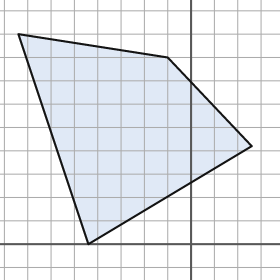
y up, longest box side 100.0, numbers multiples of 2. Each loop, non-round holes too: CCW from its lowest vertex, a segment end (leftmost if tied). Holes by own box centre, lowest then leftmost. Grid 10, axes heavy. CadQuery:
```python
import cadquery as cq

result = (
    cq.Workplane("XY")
    .moveTo(-44.0, 0.0)
    .lineTo(26.0, 42.0)
    .lineTo(-10.0, 80.0)
    .lineTo(-74.0, 90.0)
    .close()
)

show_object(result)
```